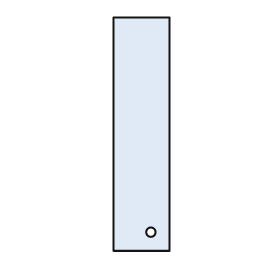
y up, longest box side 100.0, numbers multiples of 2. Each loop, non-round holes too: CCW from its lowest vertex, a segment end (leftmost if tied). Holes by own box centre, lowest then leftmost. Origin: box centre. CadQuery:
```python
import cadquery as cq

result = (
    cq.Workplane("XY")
    .moveTo(-12.0, -50.0)
    .lineTo(12.0, -50.0)
    .lineTo(12.0, 50.0)
    .lineTo(-12.0, 50.0)
    .close()
    .moveTo(4.0, -42.0)
    .circle(2.0)
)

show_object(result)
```